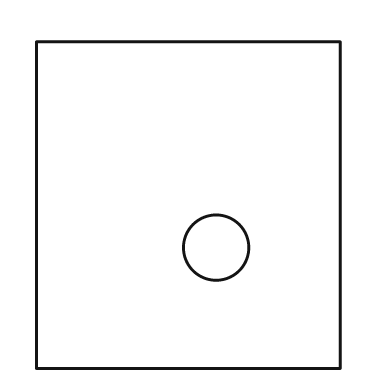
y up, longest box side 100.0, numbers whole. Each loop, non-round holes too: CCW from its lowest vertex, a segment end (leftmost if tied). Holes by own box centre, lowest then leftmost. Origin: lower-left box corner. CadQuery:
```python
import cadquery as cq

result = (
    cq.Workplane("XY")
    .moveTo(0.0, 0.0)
    .lineTo(93.0, 0.0)
    .lineTo(93.0, 100.0)
    .lineTo(0.0, 100.0)
    .close()
    .moveTo(55.0, 37.0)
    .circle(10.0)
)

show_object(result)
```